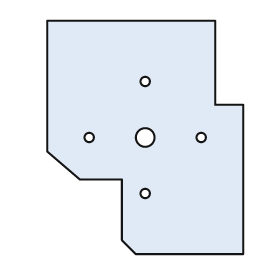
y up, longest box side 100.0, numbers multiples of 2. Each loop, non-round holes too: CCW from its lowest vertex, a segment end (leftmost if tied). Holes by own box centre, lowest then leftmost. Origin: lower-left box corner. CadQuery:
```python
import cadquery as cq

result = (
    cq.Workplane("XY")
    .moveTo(38.0, 0.0)
    .lineTo(84.0, 0.0)
    .lineTo(84.0, 64.0)
    .lineTo(72.0, 64.0)
    .lineTo(72.0, 100.0)
    .lineTo(0.0, 100.0)
    .lineTo(0.0, 44.0)
    .lineTo(14.0, 32.0)
    .lineTo(32.0, 32.0)
    .lineTo(32.0, 6.0)
    .close()
    .moveTo(42.0, 26.0)
    .circle(2.0)
    .moveTo(18.0, 50.0)
    .circle(2.0)
    .moveTo(42.0, 50.0)
    .circle(4.0)
    .moveTo(66.0, 50.0)
    .circle(2.0)
    .moveTo(42.0, 74.0)
    .circle(2.0)
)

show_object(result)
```